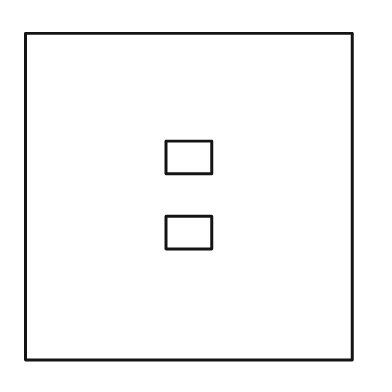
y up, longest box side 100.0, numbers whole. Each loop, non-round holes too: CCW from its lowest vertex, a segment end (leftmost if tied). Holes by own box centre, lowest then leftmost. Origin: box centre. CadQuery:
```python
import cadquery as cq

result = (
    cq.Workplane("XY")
    .moveTo(-50.0, -50.0)
    .lineTo(50.0, -50.0)
    .lineTo(50.0, 50.0)
    .lineTo(-50.0, 50.0)
    .close()
    .moveTo(-7.0, -16.0)
    .lineTo(7.0, -16.0)
    .lineTo(7.0, -6.0)
    .lineTo(-7.0, -6.0)
    .close()
    .moveTo(-7.0, 7.0)
    .lineTo(7.0, 7.0)
    .lineTo(7.0, 17.0)
    .lineTo(-7.0, 17.0)
    .close()
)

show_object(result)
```